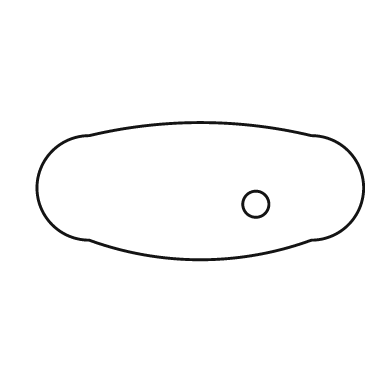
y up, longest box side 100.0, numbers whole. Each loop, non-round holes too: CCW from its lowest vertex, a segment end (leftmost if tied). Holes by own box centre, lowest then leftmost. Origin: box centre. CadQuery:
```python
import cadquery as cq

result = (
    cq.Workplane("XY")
    .moveTo(-34.0, -15.0)
    .threePointArc((0.0, -21.0), (34.0, -15.0))
    .threePointArc((50.0, 1.0), (34.0, 17.0))
    .threePointArc((0.0, 21.0), (-34.0, 17.0))
    .threePointArc((-50.0, 1.0), (-34.0, -15.0))
    .close()
    .moveTo(17.0, -4.0)
    .circle(4.0)
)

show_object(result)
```